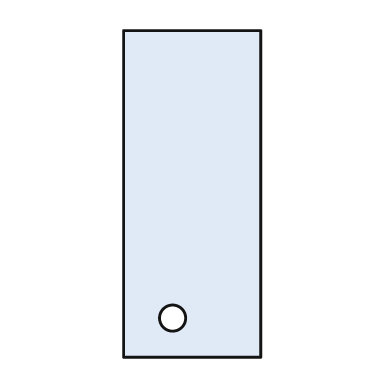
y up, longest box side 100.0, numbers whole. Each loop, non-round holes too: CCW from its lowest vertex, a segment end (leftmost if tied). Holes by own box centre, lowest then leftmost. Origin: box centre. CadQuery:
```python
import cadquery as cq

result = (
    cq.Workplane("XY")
    .moveTo(-21.0, -50.0)
    .lineTo(21.0, -50.0)
    .lineTo(21.0, 50.0)
    .lineTo(-21.0, 50.0)
    .close()
    .moveTo(-6.0, -38.0)
    .circle(4.0)
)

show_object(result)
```